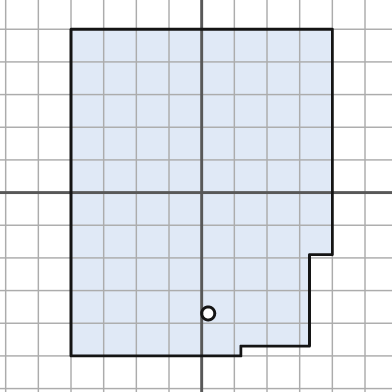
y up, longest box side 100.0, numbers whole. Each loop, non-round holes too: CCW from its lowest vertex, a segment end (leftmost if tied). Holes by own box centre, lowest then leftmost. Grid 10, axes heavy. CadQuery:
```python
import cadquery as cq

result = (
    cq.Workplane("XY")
    .moveTo(-40.0, -50.0)
    .lineTo(12.0, -50.0)
    .lineTo(12.0, -47.0)
    .lineTo(33.0, -47.0)
    .lineTo(33.0, -19.0)
    .lineTo(40.0, -19.0)
    .lineTo(40.0, 50.0)
    .lineTo(-40.0, 50.0)
    .close()
    .moveTo(2.0, -37.0)
    .circle(2.0)
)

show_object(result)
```